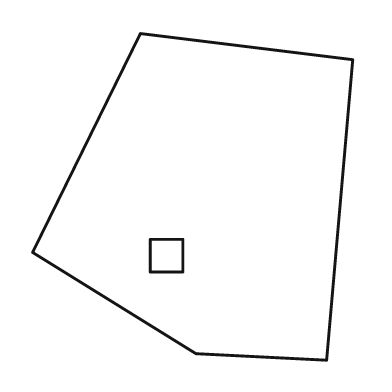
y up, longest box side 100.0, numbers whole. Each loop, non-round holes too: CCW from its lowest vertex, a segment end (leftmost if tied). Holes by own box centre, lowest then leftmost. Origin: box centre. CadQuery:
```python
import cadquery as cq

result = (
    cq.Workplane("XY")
    .moveTo(41.0, -50.0)
    .lineTo(49.0, 42.0)
    .lineTo(-16.0, 50.0)
    .lineTo(-49.0, -17.0)
    .lineTo(1.0, -48.0)
    .close()
    .moveTo(-13.0, -23.0)
    .lineTo(-3.0, -23.0)
    .lineTo(-3.0, -13.0)
    .lineTo(-13.0, -13.0)
    .close()
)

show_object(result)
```